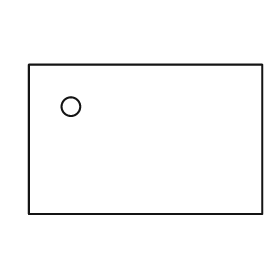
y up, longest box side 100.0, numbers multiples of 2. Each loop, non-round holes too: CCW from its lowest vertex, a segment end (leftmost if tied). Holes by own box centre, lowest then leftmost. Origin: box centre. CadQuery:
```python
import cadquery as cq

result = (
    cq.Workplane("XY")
    .moveTo(-50.0, -32.0)
    .lineTo(50.0, -32.0)
    .lineTo(50.0, 32.0)
    .lineTo(-50.0, 32.0)
    .close()
    .moveTo(-32.0, 14.0)
    .circle(4.0)
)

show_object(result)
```